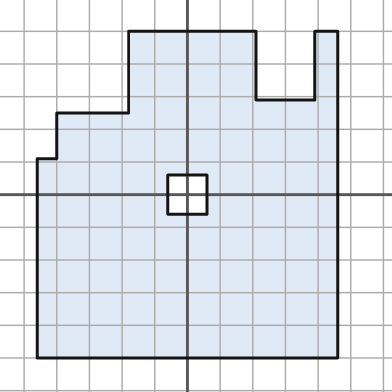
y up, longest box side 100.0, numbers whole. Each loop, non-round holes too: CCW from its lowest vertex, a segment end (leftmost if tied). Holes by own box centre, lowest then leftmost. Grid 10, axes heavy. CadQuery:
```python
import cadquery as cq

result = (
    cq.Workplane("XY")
    .moveTo(-46.0, -50.0)
    .lineTo(46.0, -50.0)
    .lineTo(46.0, 50.0)
    .lineTo(39.0, 50.0)
    .lineTo(39.0, 29.0)
    .lineTo(21.0, 29.0)
    .lineTo(21.0, 50.0)
    .lineTo(-18.0, 50.0)
    .lineTo(-18.0, 25.0)
    .lineTo(-40.0, 25.0)
    .lineTo(-40.0, 11.0)
    .lineTo(-46.0, 11.0)
    .close()
    .moveTo(-6.0, -6.0)
    .lineTo(6.0, -6.0)
    .lineTo(6.0, 6.0)
    .lineTo(-6.0, 6.0)
    .close()
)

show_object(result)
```